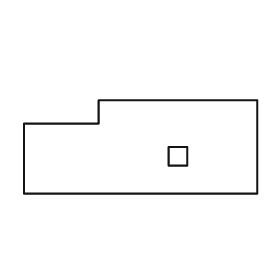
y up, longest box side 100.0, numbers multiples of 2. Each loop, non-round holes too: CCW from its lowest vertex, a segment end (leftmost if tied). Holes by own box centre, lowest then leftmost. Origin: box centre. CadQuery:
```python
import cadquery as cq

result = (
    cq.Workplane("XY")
    .moveTo(-50.0, -20.0)
    .lineTo(50.0, -20.0)
    .lineTo(50.0, 20.0)
    .lineTo(-18.0, 20.0)
    .lineTo(-18.0, 10.0)
    .lineTo(-50.0, 10.0)
    .close()
    .moveTo(12.0, -8.0)
    .lineTo(20.0, -8.0)
    .lineTo(20.0, 0.0)
    .lineTo(12.0, 0.0)
    .close()
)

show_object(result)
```